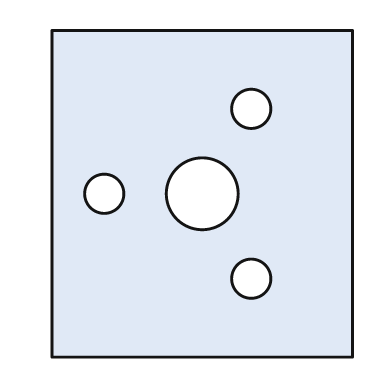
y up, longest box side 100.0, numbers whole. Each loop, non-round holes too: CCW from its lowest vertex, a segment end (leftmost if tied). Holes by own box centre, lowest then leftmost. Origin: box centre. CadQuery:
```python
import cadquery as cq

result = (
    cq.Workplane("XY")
    .moveTo(-46.0, -50.0)
    .lineTo(46.0, -50.0)
    .lineTo(46.0, 50.0)
    .lineTo(-46.0, 50.0)
    .close()
    .moveTo(15.0, -26.0)
    .circle(6.0)
    .moveTo(-30.0, 0.0)
    .circle(6.0)
    .moveTo(0.0, 0.0)
    .circle(11.0)
    .moveTo(15.0, 26.0)
    .circle(6.0)
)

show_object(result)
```